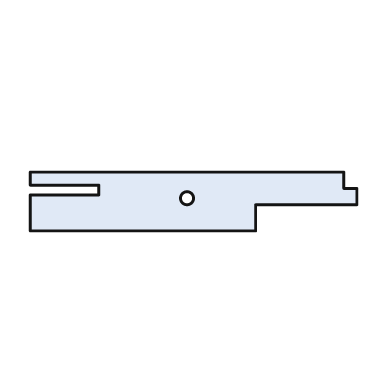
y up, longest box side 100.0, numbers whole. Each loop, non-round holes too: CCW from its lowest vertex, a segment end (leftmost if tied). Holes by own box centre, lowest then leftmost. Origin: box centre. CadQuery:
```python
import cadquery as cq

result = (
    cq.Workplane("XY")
    .moveTo(-50.0, -9.0)
    .lineTo(19.0, -9.0)
    .lineTo(19.0, -1.0)
    .lineTo(50.0, -1.0)
    .lineTo(50.0, 4.0)
    .lineTo(46.0, 4.0)
    .lineTo(46.0, 9.0)
    .lineTo(-50.0, 9.0)
    .lineTo(-50.0, 5.0)
    .lineTo(-29.0, 5.0)
    .lineTo(-29.0, 2.0)
    .lineTo(-50.0, 2.0)
    .close()
    .moveTo(-2.0, 1.0)
    .circle(2.0)
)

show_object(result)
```